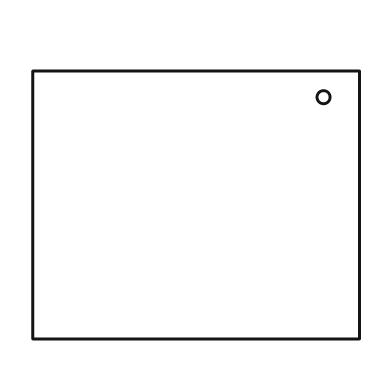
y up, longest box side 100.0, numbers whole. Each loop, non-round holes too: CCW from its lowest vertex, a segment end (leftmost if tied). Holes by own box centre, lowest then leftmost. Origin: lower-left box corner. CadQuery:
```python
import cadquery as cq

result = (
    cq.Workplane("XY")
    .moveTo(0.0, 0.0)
    .lineTo(100.0, 0.0)
    .lineTo(100.0, 82.0)
    .lineTo(0.0, 82.0)
    .close()
    .moveTo(89.0, 74.0)
    .circle(2.0)
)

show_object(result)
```